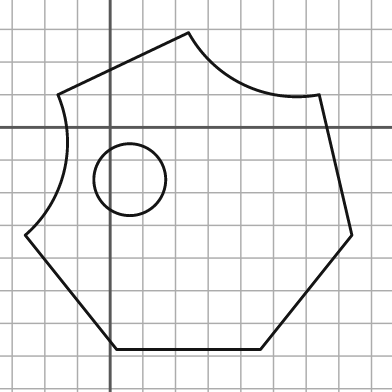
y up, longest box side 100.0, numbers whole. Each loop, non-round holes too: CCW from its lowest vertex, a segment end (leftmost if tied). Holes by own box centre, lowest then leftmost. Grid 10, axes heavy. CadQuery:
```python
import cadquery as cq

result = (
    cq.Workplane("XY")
    .moveTo(2.0, -68.0)
    .lineTo(46.0, -68.0)
    .lineTo(74.0, -33.0)
    .lineTo(64.0, 10.0)
    .threePointArc((41.0, 13.0), (24.0, 29.0))
    .lineTo(-16.0, 10.0)
    .threePointArc((-14.0, -13.0), (-26.0, -33.0))
    .close()
    .moveTo(6.0, -16.0)
    .circle(11.0)
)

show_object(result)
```